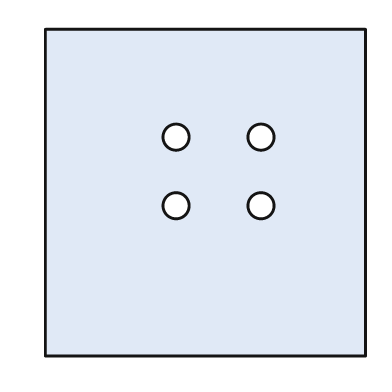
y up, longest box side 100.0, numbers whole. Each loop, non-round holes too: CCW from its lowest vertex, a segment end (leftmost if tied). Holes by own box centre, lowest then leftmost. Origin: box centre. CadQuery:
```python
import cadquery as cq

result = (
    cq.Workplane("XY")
    .moveTo(-49.0, -50.0)
    .lineTo(49.0, -50.0)
    .lineTo(49.0, 50.0)
    .lineTo(-49.0, 50.0)
    .close()
    .moveTo(-9.0, -4.0)
    .circle(4.0)
    .moveTo(17.0, -4.0)
    .circle(4.0)
    .moveTo(-9.0, 17.0)
    .circle(4.0)
    .moveTo(17.0, 17.0)
    .circle(4.0)
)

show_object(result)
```